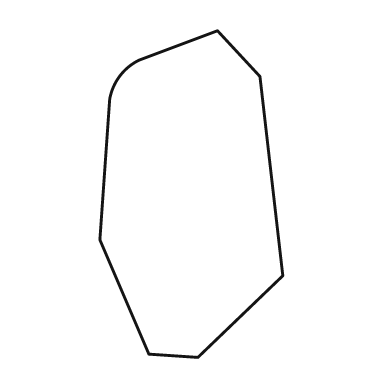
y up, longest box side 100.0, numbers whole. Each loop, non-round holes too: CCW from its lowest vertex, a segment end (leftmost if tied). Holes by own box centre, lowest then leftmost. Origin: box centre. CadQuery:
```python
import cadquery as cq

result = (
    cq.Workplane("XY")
    .moveTo(2.0, -50.0)
    .lineTo(28.0, -25.0)
    .lineTo(21.0, 36.0)
    .lineTo(8.0, 50.0)
    .lineTo(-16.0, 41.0)
    .threePointArc((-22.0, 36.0), (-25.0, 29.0))
    .lineTo(-28.0, -14.0)
    .lineTo(-13.0, -49.0)
    .close()
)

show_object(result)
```